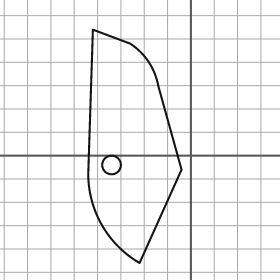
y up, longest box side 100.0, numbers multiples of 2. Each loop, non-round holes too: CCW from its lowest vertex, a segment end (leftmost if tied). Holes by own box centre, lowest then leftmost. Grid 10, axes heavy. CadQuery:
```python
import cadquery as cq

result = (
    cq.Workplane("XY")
    .moveTo(-22.0, -46.0)
    .lineTo(-4.0, -6.0)
    .lineTo(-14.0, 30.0)
    .threePointArc((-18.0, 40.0), (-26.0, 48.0))
    .lineTo(-42.0, 54.0)
    .lineTo(-44.0, -8.0)
    .threePointArc((-38.0, -30.0), (-22.0, -46.0))
    .close()
    .moveTo(-34.0, -4.0)
    .circle(4.0)
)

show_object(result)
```